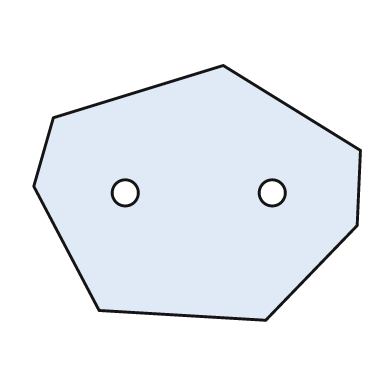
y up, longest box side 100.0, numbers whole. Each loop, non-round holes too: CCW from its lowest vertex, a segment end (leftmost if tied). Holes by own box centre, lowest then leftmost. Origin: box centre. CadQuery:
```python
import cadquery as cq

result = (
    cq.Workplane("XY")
    .moveTo(21.0, -39.0)
    .lineTo(49.0, -10.0)
    .lineTo(50.0, 13.0)
    .lineTo(8.0, 39.0)
    .lineTo(-44.0, 23.0)
    .lineTo(-50.0, 2.0)
    .lineTo(-30.0, -36.0)
    .close()
    .moveTo(-22.0, 0.0)
    .circle(4.0)
    .moveTo(23.0, 0.0)
    .circle(4.0)
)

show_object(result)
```